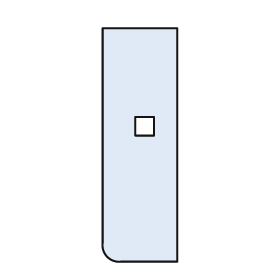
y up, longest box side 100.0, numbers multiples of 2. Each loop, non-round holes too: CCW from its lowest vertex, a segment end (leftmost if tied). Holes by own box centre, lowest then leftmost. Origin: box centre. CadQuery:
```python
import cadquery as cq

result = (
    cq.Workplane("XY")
    .moveTo(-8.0, -50.0)
    .lineTo(16.0, -50.0)
    .lineTo(16.0, 50.0)
    .lineTo(-16.0, 50.0)
    .lineTo(-16.0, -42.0)
    .threePointArc((-14.0, -48.0), (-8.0, -50.0))
    .close()
    .moveTo(-2.0, 4.0)
    .lineTo(6.0, 4.0)
    .lineTo(6.0, 12.0)
    .lineTo(-2.0, 12.0)
    .close()
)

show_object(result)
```